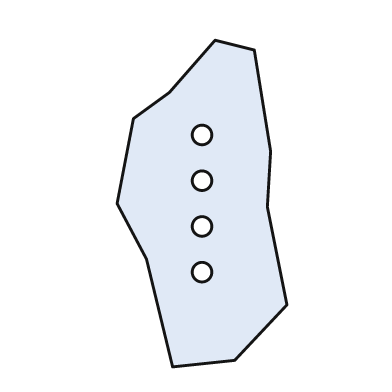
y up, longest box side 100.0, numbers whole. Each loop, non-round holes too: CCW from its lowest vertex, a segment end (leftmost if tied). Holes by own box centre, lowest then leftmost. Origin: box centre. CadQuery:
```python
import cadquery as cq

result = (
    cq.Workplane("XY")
    .moveTo(-9.0, -50.0)
    .lineTo(10.0, -48.0)
    .lineTo(26.0, -31.0)
    .lineTo(20.0, -1.0)
    .lineTo(21.0, 16.0)
    .lineTo(16.0, 47.0)
    .lineTo(4.0, 50.0)
    .lineTo(-10.0, 34.0)
    .lineTo(-21.0, 26.0)
    .lineTo(-26.0, 0.0)
    .lineTo(-17.0, -17.0)
    .close()
    .moveTo(0.0, -21.0)
    .circle(3.0)
    .moveTo(0.0, -7.0)
    .circle(3.0)
    .moveTo(0.0, 7.0)
    .circle(3.0)
    .moveTo(0.0, 21.0)
    .circle(3.0)
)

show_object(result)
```